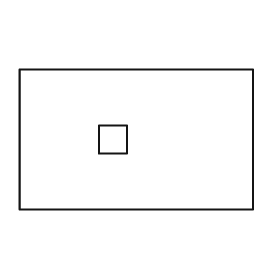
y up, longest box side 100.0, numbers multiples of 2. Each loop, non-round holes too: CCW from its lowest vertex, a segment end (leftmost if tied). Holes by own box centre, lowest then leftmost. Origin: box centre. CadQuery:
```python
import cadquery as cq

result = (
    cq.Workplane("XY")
    .moveTo(-50.0, -30.0)
    .lineTo(50.0, -30.0)
    .lineTo(50.0, 30.0)
    .lineTo(-50.0, 30.0)
    .close()
    .moveTo(-16.0, -6.0)
    .lineTo(-4.0, -6.0)
    .lineTo(-4.0, 6.0)
    .lineTo(-16.0, 6.0)
    .close()
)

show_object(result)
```